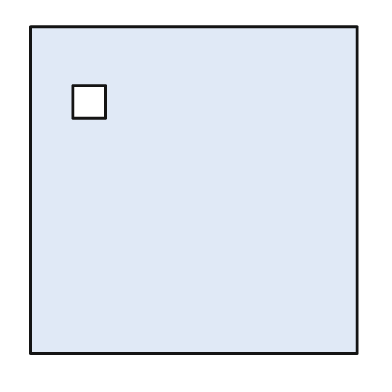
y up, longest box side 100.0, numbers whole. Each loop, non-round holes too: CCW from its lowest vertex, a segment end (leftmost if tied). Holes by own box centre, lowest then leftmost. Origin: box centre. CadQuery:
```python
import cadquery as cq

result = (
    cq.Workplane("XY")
    .moveTo(-50.0, -50.0)
    .lineTo(50.0, -50.0)
    .lineTo(50.0, 50.0)
    .lineTo(-50.0, 50.0)
    .close()
    .moveTo(-37.0, 22.0)
    .lineTo(-27.0, 22.0)
    .lineTo(-27.0, 32.0)
    .lineTo(-37.0, 32.0)
    .close()
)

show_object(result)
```